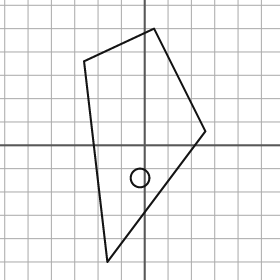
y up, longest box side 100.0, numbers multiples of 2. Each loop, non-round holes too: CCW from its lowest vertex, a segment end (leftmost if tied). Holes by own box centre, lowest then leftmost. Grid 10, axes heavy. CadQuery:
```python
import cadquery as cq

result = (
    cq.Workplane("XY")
    .moveTo(-16.0, -50.0)
    .lineTo(26.0, 6.0)
    .lineTo(4.0, 50.0)
    .lineTo(-26.0, 36.0)
    .close()
    .moveTo(-2.0, -14.0)
    .circle(4.0)
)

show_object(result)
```